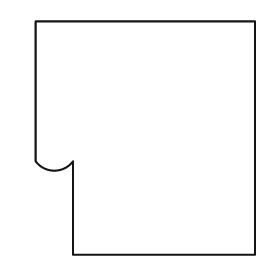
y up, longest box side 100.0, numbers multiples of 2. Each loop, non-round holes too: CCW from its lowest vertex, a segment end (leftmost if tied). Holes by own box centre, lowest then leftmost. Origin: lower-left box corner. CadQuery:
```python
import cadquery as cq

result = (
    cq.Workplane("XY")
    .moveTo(16.0, 0.0)
    .lineTo(94.0, 0.0)
    .lineTo(94.0, 100.0)
    .lineTo(0.0, 100.0)
    .lineTo(0.0, 40.0)
    .threePointArc((8.0, 36.0), (16.0, 40.0))
    .close()
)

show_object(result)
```